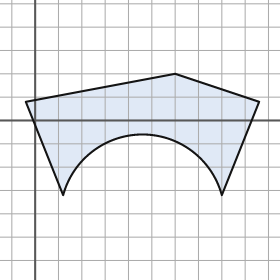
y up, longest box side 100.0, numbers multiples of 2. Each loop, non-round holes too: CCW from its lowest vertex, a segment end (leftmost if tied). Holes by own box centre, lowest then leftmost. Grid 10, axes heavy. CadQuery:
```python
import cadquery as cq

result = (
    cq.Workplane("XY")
    .moveTo(12.0, -32.0)
    .threePointArc((46.0, -6.0), (80.0, -32.0))
    .lineTo(96.0, 8.0)
    .lineTo(60.0, 20.0)
    .lineTo(-4.0, 8.0)
    .close()
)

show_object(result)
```